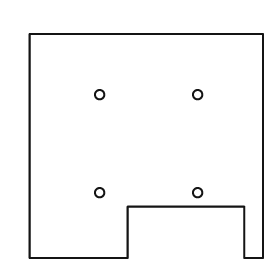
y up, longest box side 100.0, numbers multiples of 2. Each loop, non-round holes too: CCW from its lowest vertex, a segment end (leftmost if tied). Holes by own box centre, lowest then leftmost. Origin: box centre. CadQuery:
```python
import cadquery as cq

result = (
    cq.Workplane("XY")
    .moveTo(-50.0, -48.0)
    .lineTo(-8.0, -48.0)
    .lineTo(-8.0, -26.0)
    .lineTo(42.0, -26.0)
    .lineTo(42.0, -48.0)
    .lineTo(50.0, -48.0)
    .lineTo(50.0, 48.0)
    .lineTo(-50.0, 48.0)
    .close()
    .moveTo(-20.0, -20.0)
    .circle(2.0)
    .moveTo(22.0, -20.0)
    .circle(2.0)
    .moveTo(-20.0, 22.0)
    .circle(2.0)
    .moveTo(22.0, 22.0)
    .circle(2.0)
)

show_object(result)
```